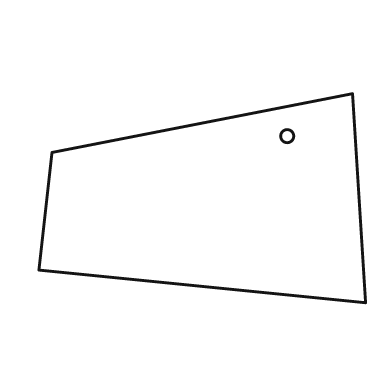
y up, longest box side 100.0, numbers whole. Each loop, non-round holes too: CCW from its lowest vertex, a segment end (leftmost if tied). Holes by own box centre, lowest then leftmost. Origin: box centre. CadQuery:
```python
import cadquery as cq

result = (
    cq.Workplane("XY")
    .moveTo(50.0, -32.0)
    .lineTo(46.0, 32.0)
    .lineTo(-46.0, 14.0)
    .lineTo(-50.0, -22.0)
    .close()
    .moveTo(26.0, 19.0)
    .circle(2.0)
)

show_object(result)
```